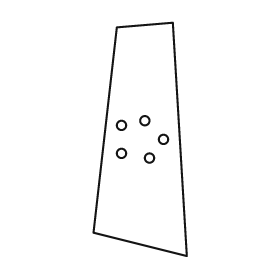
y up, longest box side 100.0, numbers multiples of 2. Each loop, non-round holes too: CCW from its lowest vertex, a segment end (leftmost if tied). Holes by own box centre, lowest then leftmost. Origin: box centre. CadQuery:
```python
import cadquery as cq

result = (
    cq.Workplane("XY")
    .moveTo(20.0, -50.0)
    .lineTo(14.0, 50.0)
    .lineTo(-10.0, 48.0)
    .lineTo(-20.0, -40.0)
    .close()
    .moveTo(4.0, -8.0)
    .circle(2.0)
    .moveTo(-8.0, -6.0)
    .circle(2.0)
    .moveTo(10.0, 0.0)
    .circle(2.0)
    .moveTo(-8.0, 6.0)
    .circle(2.0)
    .moveTo(2.0, 8.0)
    .circle(2.0)
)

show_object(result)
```